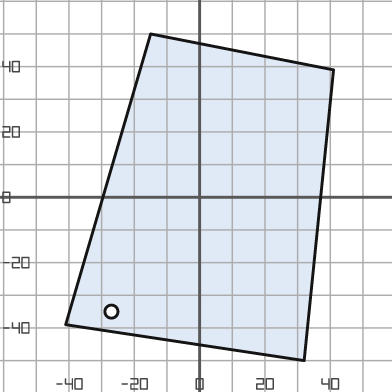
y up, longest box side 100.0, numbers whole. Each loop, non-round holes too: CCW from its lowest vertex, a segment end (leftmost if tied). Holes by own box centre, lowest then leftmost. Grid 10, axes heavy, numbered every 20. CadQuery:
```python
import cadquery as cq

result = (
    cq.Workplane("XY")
    .moveTo(32.0, -50.0)
    .lineTo(41.0, 39.0)
    .lineTo(-15.0, 50.0)
    .lineTo(-41.0, -39.0)
    .close()
    .moveTo(-27.0, -35.0)
    .circle(2.0)
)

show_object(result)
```